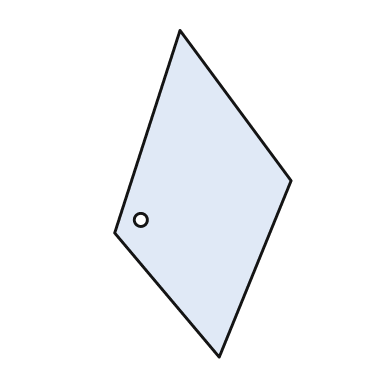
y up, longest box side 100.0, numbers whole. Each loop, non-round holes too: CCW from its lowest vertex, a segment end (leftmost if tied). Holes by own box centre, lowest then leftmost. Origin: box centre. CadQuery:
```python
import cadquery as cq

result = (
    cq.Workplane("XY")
    .moveTo(5.0, -50.0)
    .lineTo(27.0, 4.0)
    .lineTo(-7.0, 50.0)
    .lineTo(-27.0, -12.0)
    .close()
    .moveTo(-19.0, -8.0)
    .circle(2.0)
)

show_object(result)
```